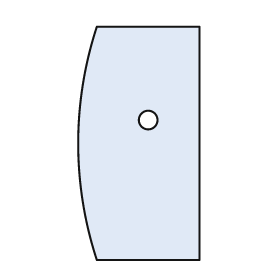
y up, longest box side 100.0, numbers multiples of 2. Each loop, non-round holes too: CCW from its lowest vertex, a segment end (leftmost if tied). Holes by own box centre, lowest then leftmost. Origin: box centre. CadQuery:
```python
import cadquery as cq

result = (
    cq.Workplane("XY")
    .moveTo(-18.0, -50.0)
    .lineTo(26.0, -50.0)
    .lineTo(26.0, 50.0)
    .lineTo(-18.0, 50.0)
    .threePointArc((-26.0, 0.0), (-18.0, -50.0))
    .close()
    .moveTo(4.0, 10.0)
    .circle(4.0)
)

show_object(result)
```